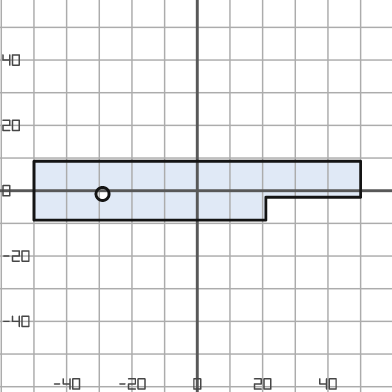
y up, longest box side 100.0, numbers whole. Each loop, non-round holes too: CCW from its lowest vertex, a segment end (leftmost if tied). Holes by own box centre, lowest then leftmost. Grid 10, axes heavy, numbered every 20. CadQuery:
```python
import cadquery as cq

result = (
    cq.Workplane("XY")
    .moveTo(-50.0, -9.0)
    .lineTo(21.0, -9.0)
    .lineTo(21.0, -2.0)
    .lineTo(50.0, -2.0)
    .lineTo(50.0, 9.0)
    .lineTo(-50.0, 9.0)
    .close()
    .moveTo(-29.0, -1.0)
    .circle(2.0)
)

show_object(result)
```